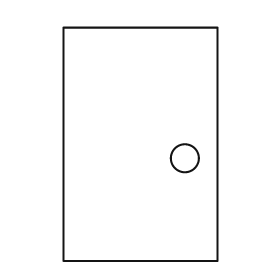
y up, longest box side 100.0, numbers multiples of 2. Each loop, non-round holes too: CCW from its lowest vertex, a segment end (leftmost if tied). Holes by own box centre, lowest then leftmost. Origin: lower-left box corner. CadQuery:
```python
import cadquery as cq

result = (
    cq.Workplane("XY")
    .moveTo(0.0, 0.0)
    .lineTo(66.0, 0.0)
    .lineTo(66.0, 100.0)
    .lineTo(0.0, 100.0)
    .close()
    .moveTo(52.0, 44.0)
    .circle(6.0)
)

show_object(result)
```